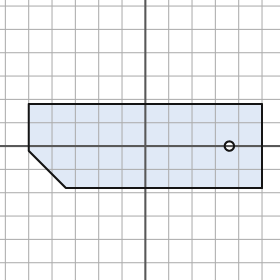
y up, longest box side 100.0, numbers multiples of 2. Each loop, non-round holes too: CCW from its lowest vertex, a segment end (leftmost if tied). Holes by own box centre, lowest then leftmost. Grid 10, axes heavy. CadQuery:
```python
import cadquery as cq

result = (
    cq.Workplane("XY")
    .moveTo(-34.0, -18.0)
    .lineTo(50.0, -18.0)
    .lineTo(50.0, 18.0)
    .lineTo(-50.0, 18.0)
    .lineTo(-50.0, -2.0)
    .close()
    .moveTo(36.0, 0.0)
    .circle(2.0)
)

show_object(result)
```